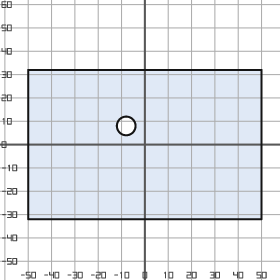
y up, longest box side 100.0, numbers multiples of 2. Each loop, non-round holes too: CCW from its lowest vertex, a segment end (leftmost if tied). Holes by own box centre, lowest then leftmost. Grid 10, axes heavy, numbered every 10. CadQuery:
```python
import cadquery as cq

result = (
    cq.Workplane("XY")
    .moveTo(-50.0, -32.0)
    .lineTo(50.0, -32.0)
    .lineTo(50.0, 32.0)
    .lineTo(-50.0, 32.0)
    .close()
    .moveTo(-8.0, 8.0)
    .circle(4.0)
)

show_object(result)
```